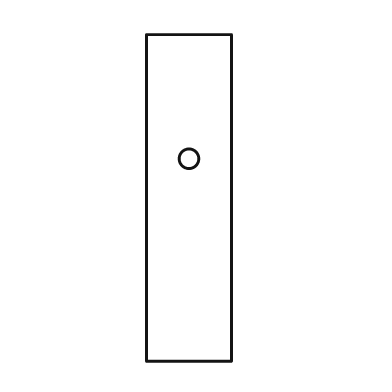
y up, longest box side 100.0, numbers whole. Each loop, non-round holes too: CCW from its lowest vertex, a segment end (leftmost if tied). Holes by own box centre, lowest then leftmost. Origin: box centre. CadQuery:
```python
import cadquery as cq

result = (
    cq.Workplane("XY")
    .moveTo(-13.0, -50.0)
    .lineTo(13.0, -50.0)
    .lineTo(13.0, 50.0)
    .lineTo(-13.0, 50.0)
    .close()
    .moveTo(0.0, 12.0)
    .circle(3.0)
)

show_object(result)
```